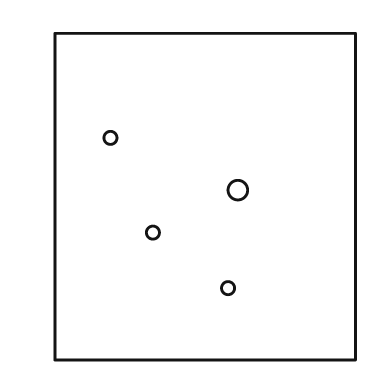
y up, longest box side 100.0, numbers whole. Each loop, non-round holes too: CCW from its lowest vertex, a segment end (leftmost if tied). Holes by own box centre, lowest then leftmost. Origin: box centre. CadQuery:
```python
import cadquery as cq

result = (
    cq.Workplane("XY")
    .moveTo(-46.0, -50.0)
    .lineTo(46.0, -50.0)
    .lineTo(46.0, 50.0)
    .lineTo(-46.0, 50.0)
    .close()
    .moveTo(7.0, -28.0)
    .circle(2.0)
    .moveTo(-16.0, -11.0)
    .circle(2.0)
    .moveTo(10.0, 2.0)
    .circle(3.0)
    .moveTo(-29.0, 18.0)
    .circle(2.0)
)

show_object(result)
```